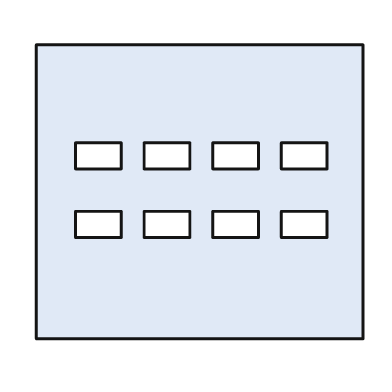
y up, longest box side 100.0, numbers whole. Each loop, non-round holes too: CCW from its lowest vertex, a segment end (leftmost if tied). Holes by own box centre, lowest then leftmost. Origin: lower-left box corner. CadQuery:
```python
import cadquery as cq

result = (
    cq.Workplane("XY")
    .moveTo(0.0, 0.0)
    .lineTo(100.0, 0.0)
    .lineTo(100.0, 90.0)
    .lineTo(0.0, 90.0)
    .close()
    .moveTo(12.0, 31.0)
    .lineTo(26.0, 31.0)
    .lineTo(26.0, 39.0)
    .lineTo(12.0, 39.0)
    .close()
    .moveTo(33.0, 31.0)
    .lineTo(47.0, 31.0)
    .lineTo(47.0, 39.0)
    .lineTo(33.0, 39.0)
    .close()
    .moveTo(54.0, 31.0)
    .lineTo(68.0, 31.0)
    .lineTo(68.0, 39.0)
    .lineTo(54.0, 39.0)
    .close()
    .moveTo(75.0, 31.0)
    .lineTo(89.0, 31.0)
    .lineTo(89.0, 39.0)
    .lineTo(75.0, 39.0)
    .close()
    .moveTo(12.0, 52.0)
    .lineTo(26.0, 52.0)
    .lineTo(26.0, 60.0)
    .lineTo(12.0, 60.0)
    .close()
    .moveTo(33.0, 52.0)
    .lineTo(47.0, 52.0)
    .lineTo(47.0, 60.0)
    .lineTo(33.0, 60.0)
    .close()
    .moveTo(54.0, 52.0)
    .lineTo(68.0, 52.0)
    .lineTo(68.0, 60.0)
    .lineTo(54.0, 60.0)
    .close()
    .moveTo(75.0, 52.0)
    .lineTo(89.0, 52.0)
    .lineTo(89.0, 60.0)
    .lineTo(75.0, 60.0)
    .close()
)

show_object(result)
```